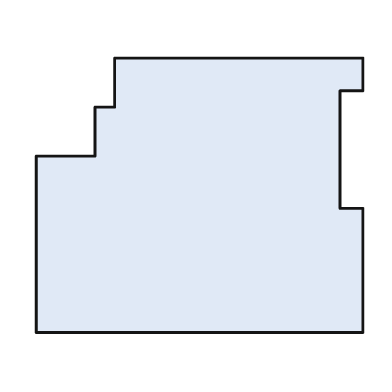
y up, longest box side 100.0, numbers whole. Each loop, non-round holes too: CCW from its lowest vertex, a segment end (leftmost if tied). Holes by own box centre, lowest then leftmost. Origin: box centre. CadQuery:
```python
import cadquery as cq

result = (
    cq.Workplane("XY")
    .moveTo(-50.0, -42.0)
    .lineTo(50.0, -42.0)
    .lineTo(50.0, -4.0)
    .lineTo(43.0, -4.0)
    .lineTo(43.0, 32.0)
    .lineTo(50.0, 32.0)
    .lineTo(50.0, 42.0)
    .lineTo(-26.0, 42.0)
    .lineTo(-26.0, 27.0)
    .lineTo(-32.0, 27.0)
    .lineTo(-32.0, 12.0)
    .lineTo(-50.0, 12.0)
    .close()
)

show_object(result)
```